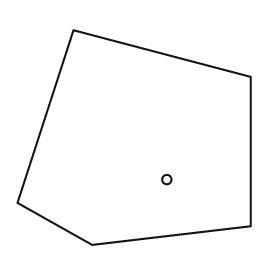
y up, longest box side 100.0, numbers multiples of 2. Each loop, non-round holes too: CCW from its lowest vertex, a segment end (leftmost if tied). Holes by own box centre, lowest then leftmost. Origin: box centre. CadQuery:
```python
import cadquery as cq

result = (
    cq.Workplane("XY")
    .moveTo(-18.0, -46.0)
    .lineTo(50.0, -38.0)
    .lineTo(50.0, 26.0)
    .lineTo(-26.0, 46.0)
    .lineTo(-50.0, -28.0)
    .close()
    .moveTo(14.0, -18.0)
    .circle(2.0)
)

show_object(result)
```